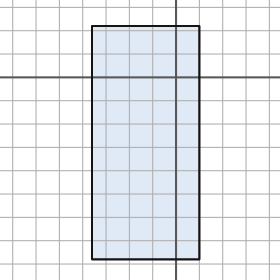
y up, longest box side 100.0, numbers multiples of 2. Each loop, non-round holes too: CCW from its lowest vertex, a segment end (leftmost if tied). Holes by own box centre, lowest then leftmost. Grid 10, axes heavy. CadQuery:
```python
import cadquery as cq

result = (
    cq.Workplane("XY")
    .moveTo(-36.0, -78.0)
    .lineTo(10.0, -78.0)
    .lineTo(10.0, 22.0)
    .lineTo(-36.0, 22.0)
    .close()
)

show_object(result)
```